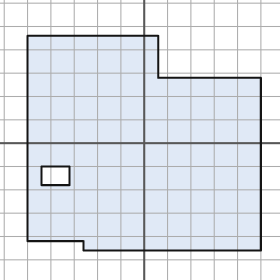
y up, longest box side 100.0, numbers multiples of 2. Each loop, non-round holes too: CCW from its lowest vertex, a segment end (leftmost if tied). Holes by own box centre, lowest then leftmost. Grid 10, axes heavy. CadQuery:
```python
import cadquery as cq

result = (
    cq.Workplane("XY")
    .moveTo(-26.0, -46.0)
    .lineTo(50.0, -46.0)
    .lineTo(50.0, 28.0)
    .lineTo(6.0, 28.0)
    .lineTo(6.0, 46.0)
    .lineTo(-50.0, 46.0)
    .lineTo(-50.0, -42.0)
    .lineTo(-26.0, -42.0)
    .close()
    .moveTo(-44.0, -18.0)
    .lineTo(-32.0, -18.0)
    .lineTo(-32.0, -10.0)
    .lineTo(-44.0, -10.0)
    .close()
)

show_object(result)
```